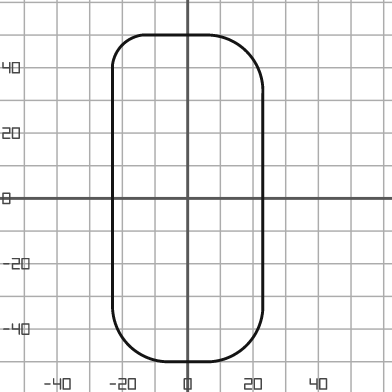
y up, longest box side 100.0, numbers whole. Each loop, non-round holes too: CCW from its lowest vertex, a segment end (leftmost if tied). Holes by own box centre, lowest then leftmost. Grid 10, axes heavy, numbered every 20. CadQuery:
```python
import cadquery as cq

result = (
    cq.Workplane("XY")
    .moveTo(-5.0, -50.0)
    .lineTo(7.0, -50.0)
    .threePointArc((18.0, -45.0), (23.0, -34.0))
    .lineTo(23.0, 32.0)
    .threePointArc((18.0, 45.0), (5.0, 50.0))
    .lineTo(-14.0, 50.0)
    .threePointArc((-20.0, 47.0), (-23.0, 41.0))
    .lineTo(-23.0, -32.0)
    .threePointArc((-18.0, -45.0), (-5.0, -50.0))
    .close()
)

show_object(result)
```